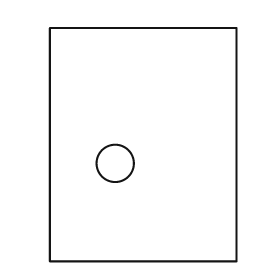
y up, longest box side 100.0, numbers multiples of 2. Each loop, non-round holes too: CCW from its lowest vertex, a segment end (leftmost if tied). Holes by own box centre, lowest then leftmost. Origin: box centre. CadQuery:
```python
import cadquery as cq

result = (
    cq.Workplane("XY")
    .moveTo(-40.0, -50.0)
    .lineTo(40.0, -50.0)
    .lineTo(40.0, 50.0)
    .lineTo(-40.0, 50.0)
    .close()
    .moveTo(-12.0, -8.0)
    .circle(8.0)
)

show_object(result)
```